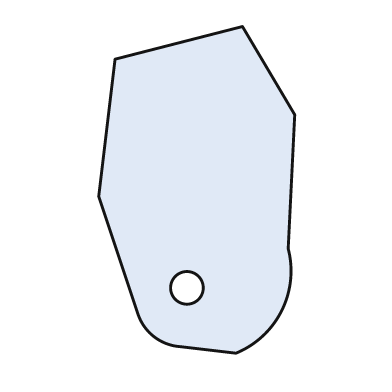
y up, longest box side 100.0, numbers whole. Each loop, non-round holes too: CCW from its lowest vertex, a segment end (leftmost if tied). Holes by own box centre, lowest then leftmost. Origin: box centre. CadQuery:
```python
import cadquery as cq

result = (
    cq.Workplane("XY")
    .moveTo(12.0, -50.0)
    .threePointArc((26.0, -37.0), (28.0, -18.0))
    .lineTo(30.0, 23.0)
    .lineTo(14.0, 50.0)
    .lineTo(-25.0, 40.0)
    .lineTo(-30.0, -2.0)
    .lineTo(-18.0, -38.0)
    .threePointArc((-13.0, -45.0), (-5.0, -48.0))
    .close()
    .moveTo(-3.0, -30.0)
    .circle(5.0)
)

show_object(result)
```